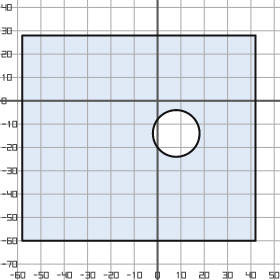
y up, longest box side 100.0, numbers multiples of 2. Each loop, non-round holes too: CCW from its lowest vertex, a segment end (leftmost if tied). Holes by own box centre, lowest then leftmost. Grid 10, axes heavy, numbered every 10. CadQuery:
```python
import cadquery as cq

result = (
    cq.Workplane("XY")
    .moveTo(-58.0, -60.0)
    .lineTo(42.0, -60.0)
    .lineTo(42.0, 28.0)
    .lineTo(-58.0, 28.0)
    .close()
    .moveTo(8.0, -14.0)
    .circle(10.0)
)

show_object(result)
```